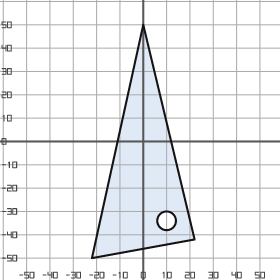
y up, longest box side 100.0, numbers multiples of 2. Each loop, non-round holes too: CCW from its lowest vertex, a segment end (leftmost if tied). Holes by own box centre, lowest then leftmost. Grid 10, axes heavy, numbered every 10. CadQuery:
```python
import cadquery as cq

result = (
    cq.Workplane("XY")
    .moveTo(-22.0, -50.0)
    .lineTo(22.0, -42.0)
    .lineTo(0.0, 50.0)
    .close()
    .moveTo(10.0, -34.0)
    .circle(4.0)
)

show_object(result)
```